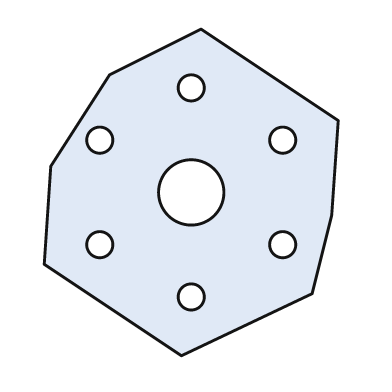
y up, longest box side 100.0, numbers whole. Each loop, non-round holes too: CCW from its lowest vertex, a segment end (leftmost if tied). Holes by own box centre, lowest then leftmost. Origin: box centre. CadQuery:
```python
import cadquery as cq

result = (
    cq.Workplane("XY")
    .moveTo(-3.0, -50.0)
    .lineTo(37.0, -31.0)
    .lineTo(43.0, -7.0)
    .lineTo(45.0, 22.0)
    .lineTo(3.0, 50.0)
    .lineTo(-25.0, 36.0)
    .lineTo(-43.0, 8.0)
    .lineTo(-45.0, -22.0)
    .close()
    .moveTo(0.0, -32.0)
    .circle(4.0)
    .moveTo(-28.0, -16.0)
    .circle(4.0)
    .moveTo(28.0, -16.0)
    .circle(4.0)
    .moveTo(0.0, 0.0)
    .circle(10.0)
    .moveTo(-28.0, 16.0)
    .circle(4.0)
    .moveTo(28.0, 16.0)
    .circle(4.0)
    .moveTo(0.0, 32.0)
    .circle(4.0)
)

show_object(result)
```